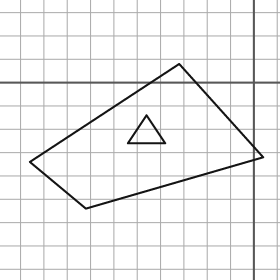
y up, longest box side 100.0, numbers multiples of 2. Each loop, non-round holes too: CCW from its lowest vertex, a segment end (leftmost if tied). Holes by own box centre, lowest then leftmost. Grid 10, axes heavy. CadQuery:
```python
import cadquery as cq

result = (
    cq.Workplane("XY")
    .moveTo(-72.0, -54.0)
    .lineTo(4.0, -32.0)
    .lineTo(-32.0, 8.0)
    .lineTo(-96.0, -34.0)
    .close()
    .moveTo(-54.0, -26.0)
    .lineTo(-38.0, -26.0)
    .lineTo(-46.0, -14.0)
    .close()
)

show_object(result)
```